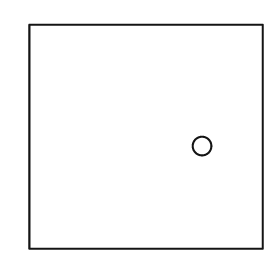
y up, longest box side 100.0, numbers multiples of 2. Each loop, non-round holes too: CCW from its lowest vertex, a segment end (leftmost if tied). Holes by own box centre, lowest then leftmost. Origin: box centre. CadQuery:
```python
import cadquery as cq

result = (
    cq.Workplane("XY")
    .moveTo(-50.0, -48.0)
    .lineTo(50.0, -48.0)
    .lineTo(50.0, 48.0)
    .lineTo(-50.0, 48.0)
    .close()
    .moveTo(24.0, -4.0)
    .circle(4.0)
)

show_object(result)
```